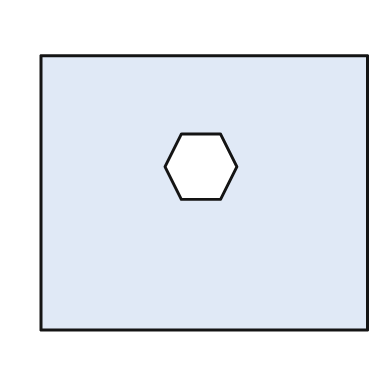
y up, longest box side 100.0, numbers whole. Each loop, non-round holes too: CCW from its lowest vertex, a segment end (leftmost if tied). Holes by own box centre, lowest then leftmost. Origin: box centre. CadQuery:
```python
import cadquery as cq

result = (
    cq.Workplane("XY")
    .moveTo(-50.0, -42.0)
    .lineTo(50.0, -42.0)
    .lineTo(50.0, 42.0)
    .lineTo(-50.0, 42.0)
    .close()
    .moveTo(-7.0, -2.0)
    .lineTo(5.0, -2.0)
    .lineTo(10.0, 8.0)
    .lineTo(5.0, 18.0)
    .lineTo(-7.0, 18.0)
    .lineTo(-12.0, 8.0)
    .close()
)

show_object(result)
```